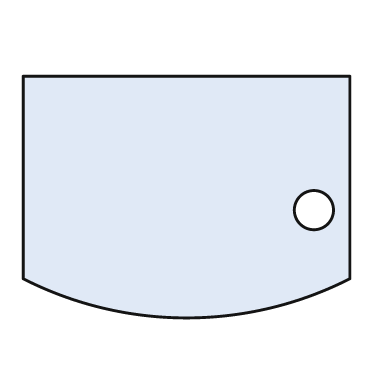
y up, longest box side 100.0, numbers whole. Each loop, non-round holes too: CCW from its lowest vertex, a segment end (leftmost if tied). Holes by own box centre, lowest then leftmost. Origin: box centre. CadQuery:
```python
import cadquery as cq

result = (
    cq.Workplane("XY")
    .moveTo(-50.0, -25.0)
    .threePointArc((0.0, -37.0), (50.0, -25.0))
    .lineTo(50.0, 37.0)
    .lineTo(-50.0, 37.0)
    .close()
    .moveTo(39.0, -4.0)
    .circle(6.0)
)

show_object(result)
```